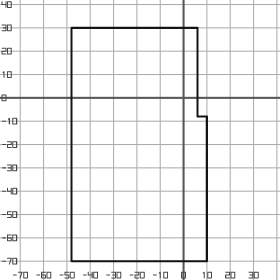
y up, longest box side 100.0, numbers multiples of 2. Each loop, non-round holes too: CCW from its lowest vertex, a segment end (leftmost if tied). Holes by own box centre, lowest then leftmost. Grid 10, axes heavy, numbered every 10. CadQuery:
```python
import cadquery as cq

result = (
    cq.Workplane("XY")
    .moveTo(-48.0, -70.0)
    .lineTo(10.0, -70.0)
    .lineTo(10.0, -8.0)
    .lineTo(6.0, -8.0)
    .lineTo(6.0, 30.0)
    .lineTo(-48.0, 30.0)
    .close()
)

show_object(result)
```